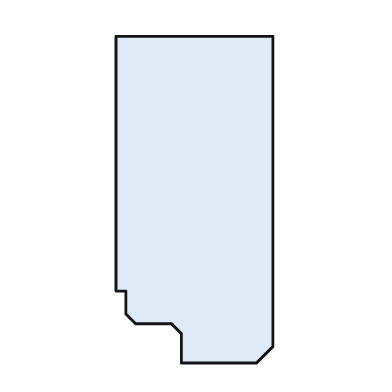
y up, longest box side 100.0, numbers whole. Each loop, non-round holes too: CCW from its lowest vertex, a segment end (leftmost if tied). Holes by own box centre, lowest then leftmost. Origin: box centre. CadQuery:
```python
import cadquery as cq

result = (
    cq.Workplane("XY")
    .moveTo(-4.0, -50.0)
    .lineTo(19.0, -50.0)
    .lineTo(24.0, -45.0)
    .lineTo(24.0, 50.0)
    .lineTo(-24.0, 50.0)
    .lineTo(-24.0, -28.0)
    .lineTo(-21.0, -28.0)
    .lineTo(-21.0, -35.0)
    .lineTo(-18.0, -38.0)
    .lineTo(-7.0, -38.0)
    .lineTo(-4.0, -41.0)
    .close()
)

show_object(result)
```